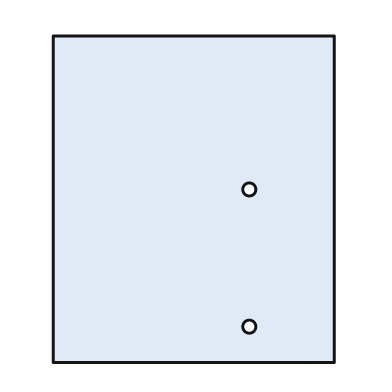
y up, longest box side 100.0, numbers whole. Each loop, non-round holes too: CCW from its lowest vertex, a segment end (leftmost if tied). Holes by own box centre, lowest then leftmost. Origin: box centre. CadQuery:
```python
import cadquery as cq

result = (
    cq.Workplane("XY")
    .moveTo(-43.0, -50.0)
    .lineTo(43.0, -50.0)
    .lineTo(43.0, 50.0)
    .lineTo(-43.0, 50.0)
    .close()
    .moveTo(17.0, -39.0)
    .circle(2.0)
    .moveTo(17.0, 3.0)
    .circle(2.0)
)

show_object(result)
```